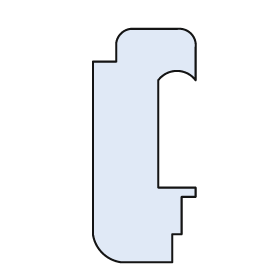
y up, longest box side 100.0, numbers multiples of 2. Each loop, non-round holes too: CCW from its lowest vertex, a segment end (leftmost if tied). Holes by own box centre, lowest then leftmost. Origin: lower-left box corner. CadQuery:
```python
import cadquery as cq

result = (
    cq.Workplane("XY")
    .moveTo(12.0, 0.0)
    .lineTo(34.0, 0.0)
    .lineTo(34.0, 12.0)
    .lineTo(38.0, 12.0)
    .lineTo(38.0, 28.0)
    .lineTo(44.0, 28.0)
    .lineTo(44.0, 32.0)
    .lineTo(28.0, 32.0)
    .lineTo(28.0, 78.0)
    .threePointArc((36.0, 82.0), (44.0, 78.0))
    .lineTo(44.0, 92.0)
    .threePointArc((42.0, 98.0), (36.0, 100.0))
    .lineTo(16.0, 100.0)
    .threePointArc((12.0, 98.0), (10.0, 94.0))
    .lineTo(10.0, 86.0)
    .lineTo(0.0, 86.0)
    .lineTo(0.0, 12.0)
    .threePointArc((4.0, 4.0), (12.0, 0.0))
    .close()
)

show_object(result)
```